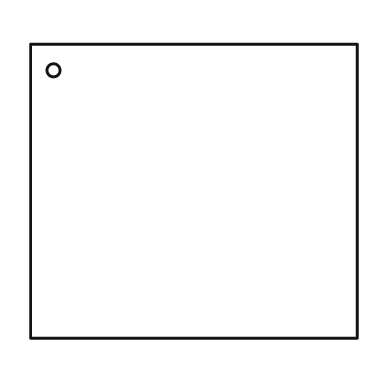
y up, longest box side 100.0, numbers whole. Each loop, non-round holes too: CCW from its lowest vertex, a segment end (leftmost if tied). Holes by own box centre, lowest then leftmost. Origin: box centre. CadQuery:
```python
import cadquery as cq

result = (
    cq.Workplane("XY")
    .moveTo(-50.0, -45.0)
    .lineTo(50.0, -45.0)
    .lineTo(50.0, 45.0)
    .lineTo(-50.0, 45.0)
    .close()
    .moveTo(-43.0, 37.0)
    .circle(2.0)
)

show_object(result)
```